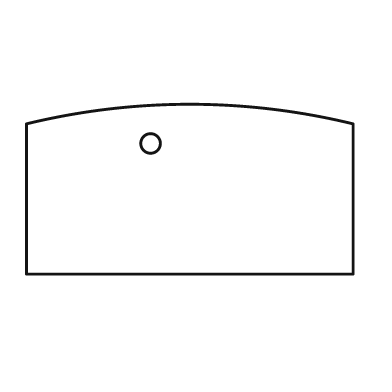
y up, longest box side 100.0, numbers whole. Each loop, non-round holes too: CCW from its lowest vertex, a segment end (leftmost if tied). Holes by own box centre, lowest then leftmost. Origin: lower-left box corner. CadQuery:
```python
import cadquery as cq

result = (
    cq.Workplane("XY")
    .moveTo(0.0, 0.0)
    .lineTo(100.0, 0.0)
    .lineTo(100.0, 46.0)
    .threePointArc((50.0, 52.0), (0.0, 46.0))
    .close()
    .moveTo(38.0, 40.0)
    .circle(3.0)
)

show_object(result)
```